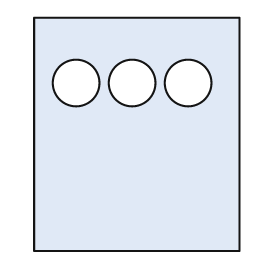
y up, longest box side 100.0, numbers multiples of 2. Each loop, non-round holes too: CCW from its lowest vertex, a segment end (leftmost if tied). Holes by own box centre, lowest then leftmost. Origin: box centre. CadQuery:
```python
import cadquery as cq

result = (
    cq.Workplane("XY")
    .moveTo(-44.0, -50.0)
    .lineTo(44.0, -50.0)
    .lineTo(44.0, 50.0)
    .lineTo(-44.0, 50.0)
    .close()
    .moveTo(-26.0, 22.0)
    .circle(10.0)
    .moveTo(-2.0, 22.0)
    .circle(10.0)
    .moveTo(22.0, 22.0)
    .circle(10.0)
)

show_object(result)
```